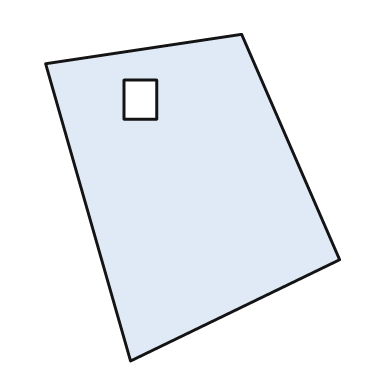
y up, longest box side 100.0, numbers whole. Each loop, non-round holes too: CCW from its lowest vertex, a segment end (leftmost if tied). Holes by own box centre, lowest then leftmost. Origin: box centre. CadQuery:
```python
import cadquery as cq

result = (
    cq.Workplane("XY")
    .moveTo(-19.0, -50.0)
    .lineTo(45.0, -19.0)
    .lineTo(15.0, 50.0)
    .lineTo(-45.0, 41.0)
    .close()
    .moveTo(-21.0, 24.0)
    .lineTo(-11.0, 24.0)
    .lineTo(-11.0, 36.0)
    .lineTo(-21.0, 36.0)
    .close()
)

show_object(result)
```